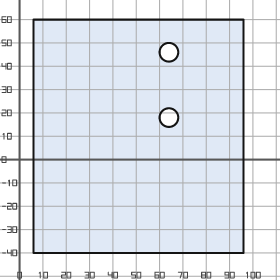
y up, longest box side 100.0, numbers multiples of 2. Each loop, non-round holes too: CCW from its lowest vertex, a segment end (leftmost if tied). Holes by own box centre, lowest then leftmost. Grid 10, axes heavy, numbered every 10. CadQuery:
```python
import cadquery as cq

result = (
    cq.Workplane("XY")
    .moveTo(6.0, -40.0)
    .lineTo(96.0, -40.0)
    .lineTo(96.0, 60.0)
    .lineTo(6.0, 60.0)
    .close()
    .moveTo(64.0, 18.0)
    .circle(4.0)
    .moveTo(64.0, 46.0)
    .circle(4.0)
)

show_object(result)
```